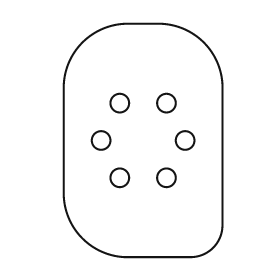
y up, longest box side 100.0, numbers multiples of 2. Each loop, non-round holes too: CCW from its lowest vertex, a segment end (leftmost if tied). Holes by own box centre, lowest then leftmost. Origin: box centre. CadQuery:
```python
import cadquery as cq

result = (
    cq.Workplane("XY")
    .moveTo(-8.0, -50.0)
    .lineTo(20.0, -50.0)
    .threePointArc((30.0, -46.0), (34.0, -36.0))
    .lineTo(34.0, 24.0)
    .threePointArc((26.0, 42.0), (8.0, 50.0))
    .lineTo(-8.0, 50.0)
    .threePointArc((-26.0, 42.0), (-34.0, 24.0))
    .lineTo(-34.0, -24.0)
    .threePointArc((-26.0, -42.0), (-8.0, -50.0))
    .close()
    .moveTo(-10.0, -16.0)
    .circle(4.0)
    .moveTo(10.0, -16.0)
    .circle(4.0)
    .moveTo(-18.0, 0.0)
    .circle(4.0)
    .moveTo(18.0, 0.0)
    .circle(4.0)
    .moveTo(-10.0, 16.0)
    .circle(4.0)
    .moveTo(10.0, 16.0)
    .circle(4.0)
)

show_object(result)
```